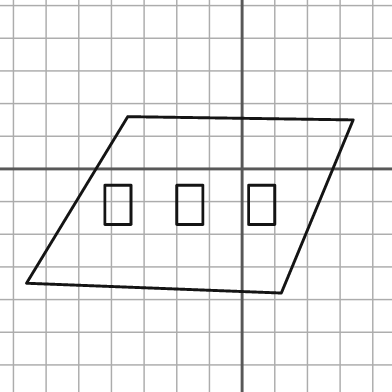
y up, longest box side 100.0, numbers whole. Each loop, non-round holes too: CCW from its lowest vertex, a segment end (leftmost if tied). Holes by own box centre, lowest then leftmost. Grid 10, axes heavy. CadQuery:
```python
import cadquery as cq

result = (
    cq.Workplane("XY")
    .moveTo(12.0, -38.0)
    .lineTo(34.0, 15.0)
    .lineTo(-35.0, 16.0)
    .lineTo(-66.0, -35.0)
    .close()
    .moveTo(-42.0, -17.0)
    .lineTo(-34.0, -17.0)
    .lineTo(-34.0, -5.0)
    .lineTo(-42.0, -5.0)
    .close()
    .moveTo(-20.0, -17.0)
    .lineTo(-12.0, -17.0)
    .lineTo(-12.0, -5.0)
    .lineTo(-20.0, -5.0)
    .close()
    .moveTo(2.0, -17.0)
    .lineTo(10.0, -17.0)
    .lineTo(10.0, -5.0)
    .lineTo(2.0, -5.0)
    .close()
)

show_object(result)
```